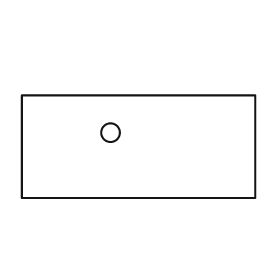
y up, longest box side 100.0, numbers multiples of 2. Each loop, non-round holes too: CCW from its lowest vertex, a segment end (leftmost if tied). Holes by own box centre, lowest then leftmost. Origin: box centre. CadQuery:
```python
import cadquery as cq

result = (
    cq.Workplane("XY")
    .moveTo(-50.0, -22.0)
    .lineTo(50.0, -22.0)
    .lineTo(50.0, 22.0)
    .lineTo(-50.0, 22.0)
    .close()
    .moveTo(-12.0, 6.0)
    .circle(4.0)
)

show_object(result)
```